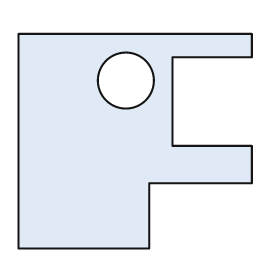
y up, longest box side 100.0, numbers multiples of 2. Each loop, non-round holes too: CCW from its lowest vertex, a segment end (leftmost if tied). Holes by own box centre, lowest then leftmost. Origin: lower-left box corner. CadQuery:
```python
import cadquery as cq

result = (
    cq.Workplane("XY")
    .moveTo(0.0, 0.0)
    .lineTo(56.0, 0.0)
    .lineTo(56.0, 28.0)
    .lineTo(100.0, 28.0)
    .lineTo(100.0, 44.0)
    .lineTo(66.0, 44.0)
    .lineTo(66.0, 82.0)
    .lineTo(100.0, 82.0)
    .lineTo(100.0, 92.0)
    .lineTo(0.0, 92.0)
    .close()
    .moveTo(46.0, 72.0)
    .circle(12.0)
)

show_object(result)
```